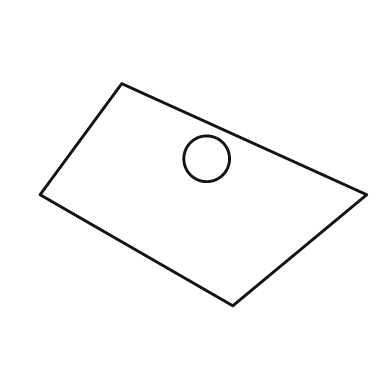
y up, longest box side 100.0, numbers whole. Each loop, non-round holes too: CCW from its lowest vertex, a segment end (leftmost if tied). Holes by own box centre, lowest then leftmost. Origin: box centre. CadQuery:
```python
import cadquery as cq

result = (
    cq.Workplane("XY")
    .moveTo(9.0, -34.0)
    .lineTo(50.0, 0.0)
    .lineTo(-25.0, 34.0)
    .lineTo(-50.0, 0.0)
    .close()
    .moveTo(1.0, 11.0)
    .circle(7.0)
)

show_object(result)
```